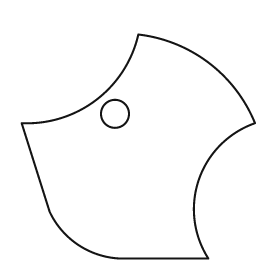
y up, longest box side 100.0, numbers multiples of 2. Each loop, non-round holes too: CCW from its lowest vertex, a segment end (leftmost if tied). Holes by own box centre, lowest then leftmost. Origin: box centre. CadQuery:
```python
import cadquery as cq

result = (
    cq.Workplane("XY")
    .moveTo(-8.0, -48.0)
    .lineTo(30.0, -48.0)
    .threePointArc((26.0, -14.0), (50.0, 10.0))
    .threePointArc((30.0, 36.0), (0.0, 48.0))
    .threePointArc((-18.0, 20.0), (-50.0, 10.0))
    .lineTo(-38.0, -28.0)
    .threePointArc((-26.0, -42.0), (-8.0, -48.0))
    .close()
    .moveTo(-10.0, 14.0)
    .circle(6.0)
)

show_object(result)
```